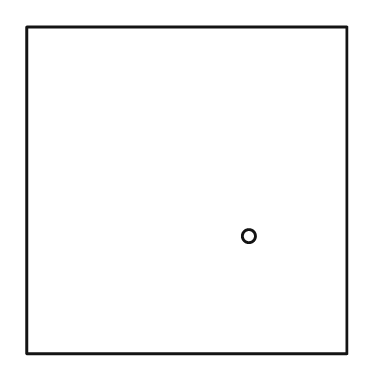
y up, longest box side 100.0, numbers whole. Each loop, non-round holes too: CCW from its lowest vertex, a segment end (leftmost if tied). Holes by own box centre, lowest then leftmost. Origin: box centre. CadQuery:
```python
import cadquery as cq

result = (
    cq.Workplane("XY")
    .moveTo(-49.0, -50.0)
    .lineTo(49.0, -50.0)
    .lineTo(49.0, 50.0)
    .lineTo(-49.0, 50.0)
    .close()
    .moveTo(19.0, -14.0)
    .circle(2.0)
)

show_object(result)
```